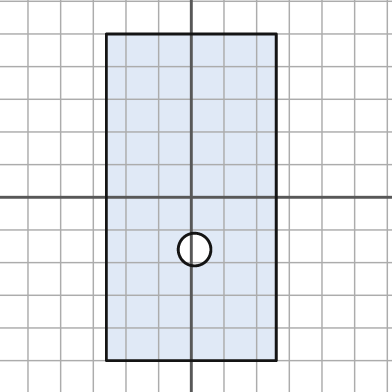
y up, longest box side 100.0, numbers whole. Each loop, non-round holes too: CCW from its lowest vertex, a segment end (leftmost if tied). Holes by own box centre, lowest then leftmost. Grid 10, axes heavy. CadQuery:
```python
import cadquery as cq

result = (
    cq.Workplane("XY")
    .moveTo(-26.0, -50.0)
    .lineTo(26.0, -50.0)
    .lineTo(26.0, 50.0)
    .lineTo(-26.0, 50.0)
    .close()
    .moveTo(1.0, -16.0)
    .circle(5.0)
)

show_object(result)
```